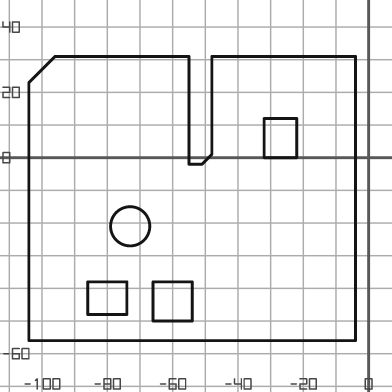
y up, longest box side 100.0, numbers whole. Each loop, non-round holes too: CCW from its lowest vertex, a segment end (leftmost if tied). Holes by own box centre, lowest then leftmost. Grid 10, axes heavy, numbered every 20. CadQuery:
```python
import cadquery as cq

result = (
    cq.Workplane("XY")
    .moveTo(-104.0, -56.0)
    .lineTo(-4.0, -56.0)
    .lineTo(-4.0, 31.0)
    .lineTo(-48.0, 31.0)
    .lineTo(-48.0, 1.0)
    .lineTo(-51.0, -2.0)
    .lineTo(-55.0, -2.0)
    .lineTo(-55.0, 31.0)
    .lineTo(-96.0, 31.0)
    .lineTo(-104.0, 23.0)
    .close()
    .moveTo(-66.0, -50.0)
    .lineTo(-54.0, -50.0)
    .lineTo(-54.0, -38.0)
    .lineTo(-66.0, -38.0)
    .close()
    .moveTo(-86.0, -48.0)
    .lineTo(-74.0, -48.0)
    .lineTo(-74.0, -38.0)
    .lineTo(-86.0, -38.0)
    .close()
    .moveTo(-73.0, -21.0)
    .circle(6.0)
    .moveTo(-32.0, 0.0)
    .lineTo(-22.0, 0.0)
    .lineTo(-22.0, 12.0)
    .lineTo(-32.0, 12.0)
    .close()
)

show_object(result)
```